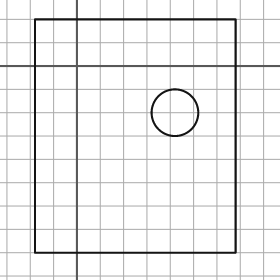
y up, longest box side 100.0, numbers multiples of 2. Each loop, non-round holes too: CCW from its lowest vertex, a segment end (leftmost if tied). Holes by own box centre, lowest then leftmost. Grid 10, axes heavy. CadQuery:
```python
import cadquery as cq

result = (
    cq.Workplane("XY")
    .moveTo(-18.0, -80.0)
    .lineTo(68.0, -80.0)
    .lineTo(68.0, 20.0)
    .lineTo(-18.0, 20.0)
    .close()
    .moveTo(42.0, -20.0)
    .circle(10.0)
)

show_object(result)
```